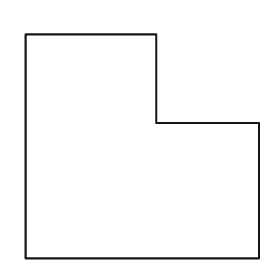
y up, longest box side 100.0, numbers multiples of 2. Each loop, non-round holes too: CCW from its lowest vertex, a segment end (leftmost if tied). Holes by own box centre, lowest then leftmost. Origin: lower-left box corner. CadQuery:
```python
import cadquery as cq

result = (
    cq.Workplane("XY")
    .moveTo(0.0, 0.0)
    .lineTo(100.0, 0.0)
    .lineTo(100.0, 58.0)
    .lineTo(56.0, 58.0)
    .lineTo(56.0, 96.0)
    .lineTo(0.0, 96.0)
    .close()
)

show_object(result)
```